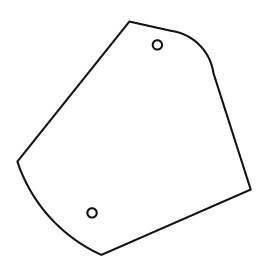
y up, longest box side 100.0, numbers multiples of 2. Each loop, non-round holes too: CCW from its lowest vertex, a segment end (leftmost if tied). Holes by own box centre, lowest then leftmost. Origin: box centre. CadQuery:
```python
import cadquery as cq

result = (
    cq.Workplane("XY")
    .moveTo(-14.0, -50.0)
    .lineTo(50.0, -22.0)
    .lineTo(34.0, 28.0)
    .threePointArc((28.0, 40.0), (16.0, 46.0))
    .lineTo(-2.0, 50.0)
    .lineTo(-50.0, -10.0)
    .threePointArc((-36.0, -34.0), (-14.0, -50.0))
    .close()
    .moveTo(-18.0, -32.0)
    .circle(2.0)
    .moveTo(10.0, 40.0)
    .circle(2.0)
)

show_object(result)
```